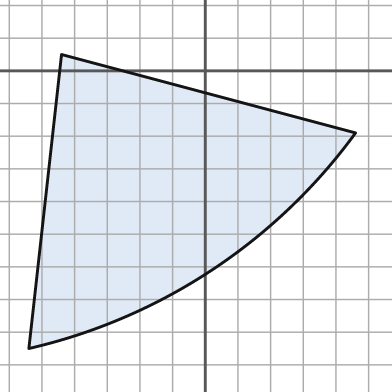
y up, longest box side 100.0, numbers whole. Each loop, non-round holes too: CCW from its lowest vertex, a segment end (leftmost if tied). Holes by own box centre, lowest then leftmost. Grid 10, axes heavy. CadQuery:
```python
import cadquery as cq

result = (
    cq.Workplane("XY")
    .moveTo(-54.0, -85.0)
    .threePointArc((2.0, -61.0), (46.0, -19.0))
    .lineTo(-44.0, 5.0)
    .close()
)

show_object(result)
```